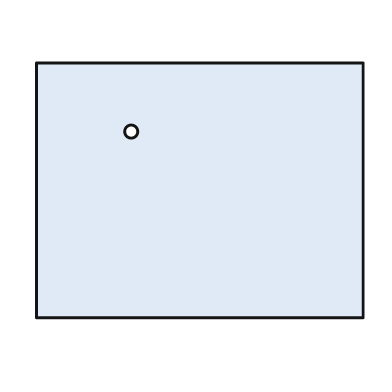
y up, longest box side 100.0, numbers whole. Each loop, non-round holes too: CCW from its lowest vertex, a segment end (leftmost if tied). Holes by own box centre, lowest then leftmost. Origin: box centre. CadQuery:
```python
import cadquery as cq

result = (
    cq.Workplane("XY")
    .moveTo(-50.0, -39.0)
    .lineTo(50.0, -39.0)
    .lineTo(50.0, 39.0)
    .lineTo(-50.0, 39.0)
    .close()
    .moveTo(-21.0, 18.0)
    .circle(2.0)
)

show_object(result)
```